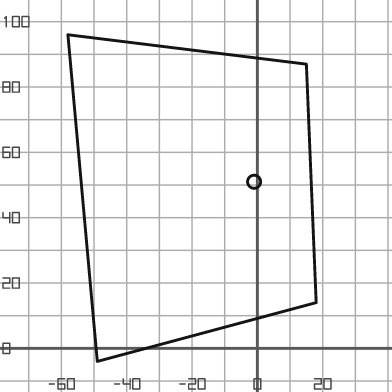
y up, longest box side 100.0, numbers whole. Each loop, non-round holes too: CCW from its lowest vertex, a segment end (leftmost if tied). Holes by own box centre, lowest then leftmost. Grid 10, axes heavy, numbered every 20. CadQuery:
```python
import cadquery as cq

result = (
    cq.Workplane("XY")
    .moveTo(-49.0, -4.0)
    .lineTo(18.0, 14.0)
    .lineTo(15.0, 87.0)
    .lineTo(-58.0, 96.0)
    .close()
    .moveTo(-1.0, 51.0)
    .circle(2.0)
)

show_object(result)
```